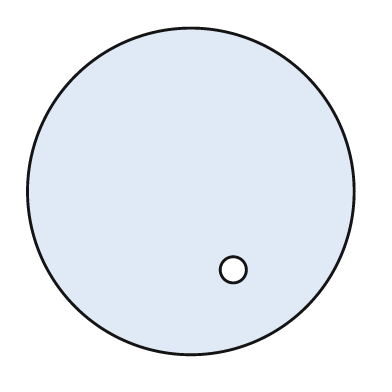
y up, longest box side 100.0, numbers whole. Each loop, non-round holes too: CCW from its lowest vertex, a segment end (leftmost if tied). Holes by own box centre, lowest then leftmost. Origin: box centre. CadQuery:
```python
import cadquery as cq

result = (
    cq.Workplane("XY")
    .moveTo(0.0, 0.0)
    .circle(50.0)
    .moveTo(13.0, -24.0)
    .circle(4.0)
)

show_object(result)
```